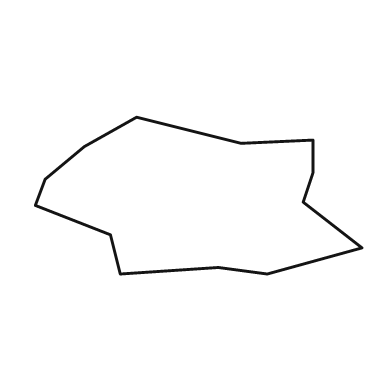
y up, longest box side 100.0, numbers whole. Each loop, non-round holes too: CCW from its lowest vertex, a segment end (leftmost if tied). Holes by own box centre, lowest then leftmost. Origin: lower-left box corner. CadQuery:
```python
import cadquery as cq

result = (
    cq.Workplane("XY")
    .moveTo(26.0, 0.0)
    .lineTo(56.0, 2.0)
    .lineTo(71.0, 0.0)
    .lineTo(100.0, 8.0)
    .lineTo(82.0, 22.0)
    .lineTo(85.0, 31.0)
    .lineTo(85.0, 41.0)
    .lineTo(63.0, 40.0)
    .lineTo(31.0, 48.0)
    .lineTo(15.0, 39.0)
    .lineTo(3.0, 29.0)
    .lineTo(0.0, 21.0)
    .lineTo(23.0, 12.0)
    .close()
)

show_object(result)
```